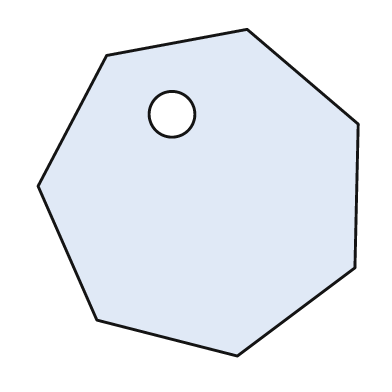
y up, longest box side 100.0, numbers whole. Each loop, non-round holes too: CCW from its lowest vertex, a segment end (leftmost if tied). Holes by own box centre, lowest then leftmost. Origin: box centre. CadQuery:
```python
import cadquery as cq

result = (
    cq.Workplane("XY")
    .moveTo(12.0, -50.0)
    .lineTo(48.0, -23.0)
    .lineTo(49.0, 21.0)
    .lineTo(15.0, 50.0)
    .lineTo(-28.0, 42.0)
    .lineTo(-49.0, 2.0)
    .lineTo(-31.0, -39.0)
    .close()
    .moveTo(-8.0, 24.0)
    .circle(7.0)
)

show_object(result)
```